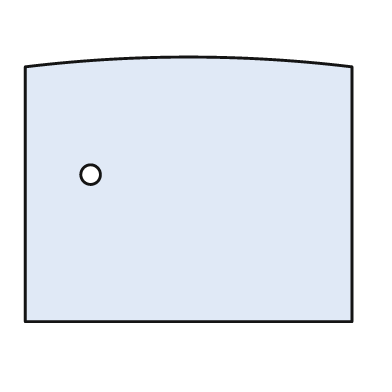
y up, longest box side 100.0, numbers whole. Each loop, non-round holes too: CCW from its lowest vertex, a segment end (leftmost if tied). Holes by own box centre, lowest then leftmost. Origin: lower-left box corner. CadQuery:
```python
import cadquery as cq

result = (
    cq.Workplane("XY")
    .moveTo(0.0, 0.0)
    .lineTo(100.0, 0.0)
    .lineTo(100.0, 78.0)
    .threePointArc((50.0, 81.0), (0.0, 78.0))
    .close()
    .moveTo(20.0, 45.0)
    .circle(3.0)
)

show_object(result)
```